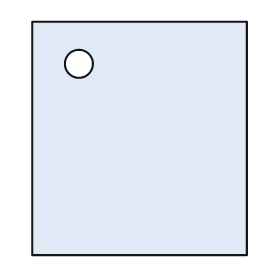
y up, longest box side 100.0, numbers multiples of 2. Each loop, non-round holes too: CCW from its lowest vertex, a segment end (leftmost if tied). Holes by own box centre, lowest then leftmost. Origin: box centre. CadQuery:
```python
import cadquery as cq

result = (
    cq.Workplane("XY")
    .moveTo(-46.0, -50.0)
    .lineTo(46.0, -50.0)
    .lineTo(46.0, 50.0)
    .lineTo(-46.0, 50.0)
    .close()
    .moveTo(-26.0, 32.0)
    .circle(6.0)
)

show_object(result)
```